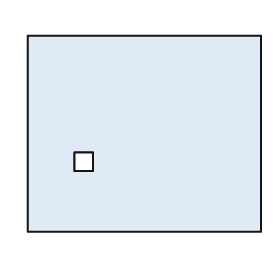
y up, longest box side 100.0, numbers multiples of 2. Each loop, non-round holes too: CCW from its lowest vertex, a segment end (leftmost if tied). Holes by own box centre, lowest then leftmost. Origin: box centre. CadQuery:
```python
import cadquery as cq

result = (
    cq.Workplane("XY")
    .moveTo(-50.0, -42.0)
    .lineTo(50.0, -42.0)
    .lineTo(50.0, 42.0)
    .lineTo(-50.0, 42.0)
    .close()
    .moveTo(-30.0, -16.0)
    .lineTo(-22.0, -16.0)
    .lineTo(-22.0, -8.0)
    .lineTo(-30.0, -8.0)
    .close()
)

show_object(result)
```